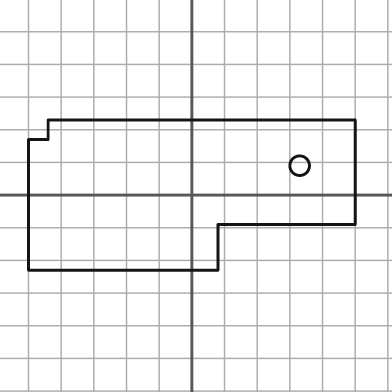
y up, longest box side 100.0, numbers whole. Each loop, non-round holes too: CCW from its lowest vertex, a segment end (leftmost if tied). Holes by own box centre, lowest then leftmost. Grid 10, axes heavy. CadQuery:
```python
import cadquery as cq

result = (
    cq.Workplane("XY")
    .moveTo(-50.0, -23.0)
    .lineTo(8.0, -23.0)
    .lineTo(8.0, -9.0)
    .lineTo(50.0, -9.0)
    .lineTo(50.0, 23.0)
    .lineTo(-44.0, 23.0)
    .lineTo(-44.0, 17.0)
    .lineTo(-50.0, 17.0)
    .close()
    .moveTo(33.0, 9.0)
    .circle(3.0)
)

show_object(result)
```